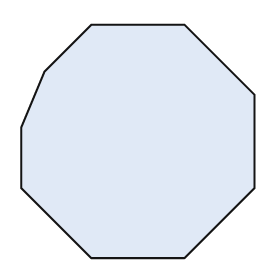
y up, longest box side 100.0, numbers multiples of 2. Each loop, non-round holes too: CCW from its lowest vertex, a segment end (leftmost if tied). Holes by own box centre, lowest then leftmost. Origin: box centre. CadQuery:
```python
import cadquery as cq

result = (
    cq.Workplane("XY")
    .moveTo(-20.0, -50.0)
    .lineTo(20.0, -50.0)
    .lineTo(50.0, -20.0)
    .lineTo(50.0, 20.0)
    .lineTo(20.0, 50.0)
    .lineTo(-20.0, 50.0)
    .lineTo(-40.0, 30.0)
    .lineTo(-50.0, 6.0)
    .lineTo(-50.0, -20.0)
    .close()
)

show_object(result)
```